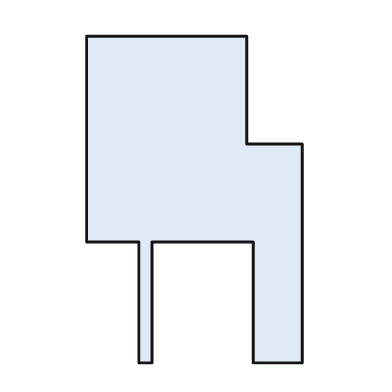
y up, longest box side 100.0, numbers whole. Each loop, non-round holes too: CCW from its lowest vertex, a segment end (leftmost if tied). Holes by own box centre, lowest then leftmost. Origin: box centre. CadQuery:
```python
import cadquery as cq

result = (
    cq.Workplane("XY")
    .moveTo(-17.0, -50.0)
    .lineTo(-13.0, -50.0)
    .lineTo(-13.0, -13.0)
    .lineTo(18.0, -13.0)
    .lineTo(18.0, -50.0)
    .lineTo(33.0, -50.0)
    .lineTo(33.0, 17.0)
    .lineTo(16.0, 17.0)
    .lineTo(16.0, 50.0)
    .lineTo(-33.0, 50.0)
    .lineTo(-33.0, -13.0)
    .lineTo(-17.0, -13.0)
    .close()
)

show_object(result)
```